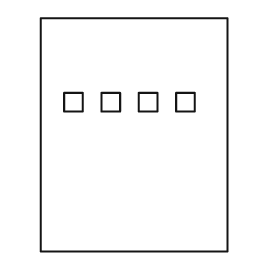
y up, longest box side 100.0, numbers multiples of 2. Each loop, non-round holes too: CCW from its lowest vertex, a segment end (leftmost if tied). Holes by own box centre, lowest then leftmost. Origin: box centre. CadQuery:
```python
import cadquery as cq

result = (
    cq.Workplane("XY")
    .moveTo(-40.0, -50.0)
    .lineTo(40.0, -50.0)
    .lineTo(40.0, 50.0)
    .lineTo(-40.0, 50.0)
    .close()
    .moveTo(-30.0, 10.0)
    .lineTo(-22.0, 10.0)
    .lineTo(-22.0, 18.0)
    .lineTo(-30.0, 18.0)
    .close()
    .moveTo(-14.0, 10.0)
    .lineTo(-6.0, 10.0)
    .lineTo(-6.0, 18.0)
    .lineTo(-14.0, 18.0)
    .close()
    .moveTo(2.0, 10.0)
    .lineTo(10.0, 10.0)
    .lineTo(10.0, 18.0)
    .lineTo(2.0, 18.0)
    .close()
    .moveTo(18.0, 10.0)
    .lineTo(26.0, 10.0)
    .lineTo(26.0, 18.0)
    .lineTo(18.0, 18.0)
    .close()
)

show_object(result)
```